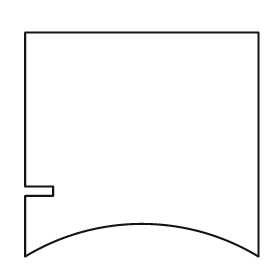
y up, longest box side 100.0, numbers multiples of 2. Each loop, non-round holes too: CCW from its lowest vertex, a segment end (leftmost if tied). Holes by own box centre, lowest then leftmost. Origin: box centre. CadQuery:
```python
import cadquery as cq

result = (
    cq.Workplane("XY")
    .moveTo(-50.0, -48.0)
    .threePointArc((0.0, -34.0), (50.0, -48.0))
    .lineTo(50.0, 48.0)
    .lineTo(-50.0, 48.0)
    .lineTo(-50.0, -18.0)
    .lineTo(-38.0, -18.0)
    .lineTo(-38.0, -22.0)
    .lineTo(-50.0, -22.0)
    .close()
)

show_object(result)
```